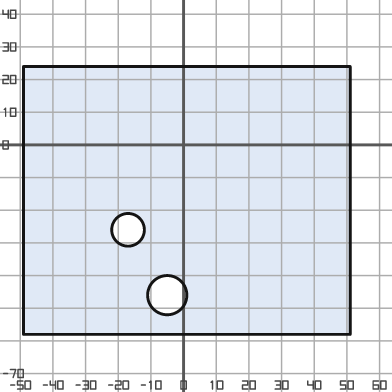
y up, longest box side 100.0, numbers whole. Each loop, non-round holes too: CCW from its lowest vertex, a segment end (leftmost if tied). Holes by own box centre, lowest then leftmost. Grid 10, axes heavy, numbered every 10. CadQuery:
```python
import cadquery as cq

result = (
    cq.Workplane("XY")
    .moveTo(-49.0, -58.0)
    .lineTo(51.0, -58.0)
    .lineTo(51.0, 24.0)
    .lineTo(-49.0, 24.0)
    .close()
    .moveTo(-5.0, -46.0)
    .circle(6.0)
    .moveTo(-17.0, -26.0)
    .circle(5.0)
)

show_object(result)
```